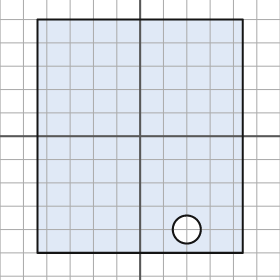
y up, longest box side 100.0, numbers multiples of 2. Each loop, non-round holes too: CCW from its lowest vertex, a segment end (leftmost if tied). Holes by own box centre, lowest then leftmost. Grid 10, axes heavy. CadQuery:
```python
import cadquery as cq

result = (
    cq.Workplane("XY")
    .moveTo(-44.0, -50.0)
    .lineTo(44.0, -50.0)
    .lineTo(44.0, 50.0)
    .lineTo(-44.0, 50.0)
    .close()
    .moveTo(20.0, -40.0)
    .circle(6.0)
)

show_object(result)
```